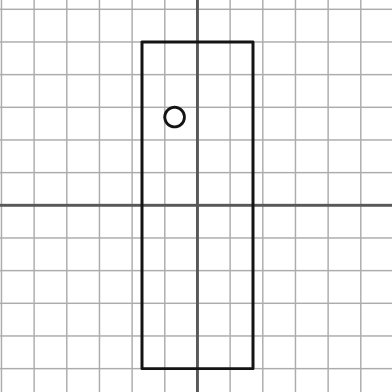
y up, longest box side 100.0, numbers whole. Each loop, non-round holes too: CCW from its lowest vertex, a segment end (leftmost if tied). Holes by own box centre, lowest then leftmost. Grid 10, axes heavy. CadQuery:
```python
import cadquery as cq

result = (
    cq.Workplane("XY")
    .moveTo(-17.0, -50.0)
    .lineTo(17.0, -50.0)
    .lineTo(17.0, 50.0)
    .lineTo(-17.0, 50.0)
    .close()
    .moveTo(-7.0, 27.0)
    .circle(3.0)
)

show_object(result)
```